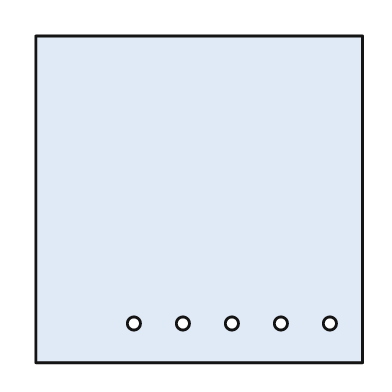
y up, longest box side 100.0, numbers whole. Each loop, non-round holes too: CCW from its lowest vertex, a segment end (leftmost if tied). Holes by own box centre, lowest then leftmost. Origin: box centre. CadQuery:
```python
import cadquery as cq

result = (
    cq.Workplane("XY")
    .moveTo(-50.0, -50.0)
    .lineTo(50.0, -50.0)
    .lineTo(50.0, 50.0)
    .lineTo(-50.0, 50.0)
    .close()
    .moveTo(-20.0, -38.0)
    .circle(2.0)
    .moveTo(-5.0, -38.0)
    .circle(2.0)
    .moveTo(10.0, -38.0)
    .circle(2.0)
    .moveTo(25.0, -38.0)
    .circle(2.0)
    .moveTo(40.0, -38.0)
    .circle(2.0)
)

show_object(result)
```